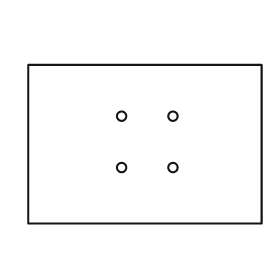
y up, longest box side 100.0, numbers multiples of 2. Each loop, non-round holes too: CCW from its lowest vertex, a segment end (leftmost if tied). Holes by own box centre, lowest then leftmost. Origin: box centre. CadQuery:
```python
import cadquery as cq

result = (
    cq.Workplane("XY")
    .moveTo(-50.0, -34.0)
    .lineTo(50.0, -34.0)
    .lineTo(50.0, 34.0)
    .lineTo(-50.0, 34.0)
    .close()
    .moveTo(-10.0, -10.0)
    .circle(2.0)
    .moveTo(12.0, -10.0)
    .circle(2.0)
    .moveTo(-10.0, 12.0)
    .circle(2.0)
    .moveTo(12.0, 12.0)
    .circle(2.0)
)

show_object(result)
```